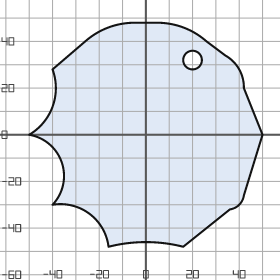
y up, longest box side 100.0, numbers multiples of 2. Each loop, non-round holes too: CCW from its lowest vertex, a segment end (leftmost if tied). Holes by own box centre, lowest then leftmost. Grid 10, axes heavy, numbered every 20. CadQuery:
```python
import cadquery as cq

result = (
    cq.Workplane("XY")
    .moveTo(-16.0, -48.0)
    .threePointArc((0.0, -46.0), (16.0, -48.0))
    .lineTo(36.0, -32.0)
    .threePointArc((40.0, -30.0), (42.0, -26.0))
    .lineTo(50.0, 0.0)
    .lineTo(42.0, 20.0)
    .threePointArc((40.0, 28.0), (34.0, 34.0))
    .lineTo(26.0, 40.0)
    .threePointArc((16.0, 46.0), (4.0, 48.0))
    .lineTo(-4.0, 48.0)
    .threePointArc((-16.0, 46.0), (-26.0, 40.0))
    .lineTo(-40.0, 28.0)
    .threePointArc((-40.0, 12.0), (-50.0, 0.0))
    .threePointArc((-36.0, -12.0), (-40.0, -30.0))
    .threePointArc((-24.0, -34.0), (-16.0, -48.0))
    .close()
    .moveTo(20.0, 32.0)
    .circle(4.0)
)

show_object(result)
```